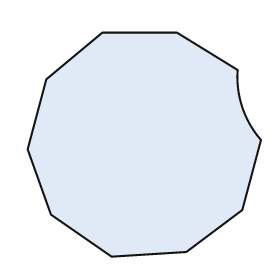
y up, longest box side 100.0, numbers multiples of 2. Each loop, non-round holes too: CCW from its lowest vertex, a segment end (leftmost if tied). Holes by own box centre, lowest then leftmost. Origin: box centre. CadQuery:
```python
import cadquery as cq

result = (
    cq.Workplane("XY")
    .moveTo(-14.0, -48.0)
    .lineTo(18.0, -46.0)
    .lineTo(42.0, -28.0)
    .lineTo(50.0, 2.0)
    .threePointArc((42.0, 16.0), (40.0, 32.0))
    .lineTo(14.0, 48.0)
    .lineTo(-18.0, 48.0)
    .lineTo(-42.0, 28.0)
    .lineTo(-50.0, -2.0)
    .lineTo(-40.0, -30.0)
    .close()
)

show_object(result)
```